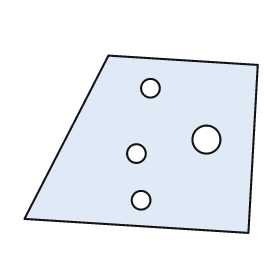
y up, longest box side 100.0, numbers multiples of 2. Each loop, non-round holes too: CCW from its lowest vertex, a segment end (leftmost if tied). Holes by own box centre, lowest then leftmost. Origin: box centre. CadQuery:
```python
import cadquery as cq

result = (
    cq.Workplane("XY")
    .moveTo(46.0, -38.0)
    .lineTo(50.0, 34.0)
    .lineTo(-14.0, 38.0)
    .lineTo(-50.0, -32.0)
    .close()
    .moveTo(0.0, -24.0)
    .circle(4.0)
    .moveTo(-2.0, -4.0)
    .circle(4.0)
    .moveTo(28.0, 2.0)
    .circle(6.0)
    .moveTo(4.0, 24.0)
    .circle(4.0)
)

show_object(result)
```